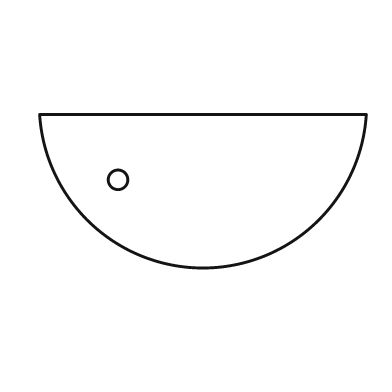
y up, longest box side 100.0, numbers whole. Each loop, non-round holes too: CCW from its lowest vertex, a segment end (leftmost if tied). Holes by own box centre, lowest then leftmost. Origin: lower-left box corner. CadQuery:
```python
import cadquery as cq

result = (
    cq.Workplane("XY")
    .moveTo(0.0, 47.0)
    .threePointArc((50.0, 0.0), (100.0, 47.0))
    .close()
    .moveTo(24.0, 27.0)
    .circle(3.0)
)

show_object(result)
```